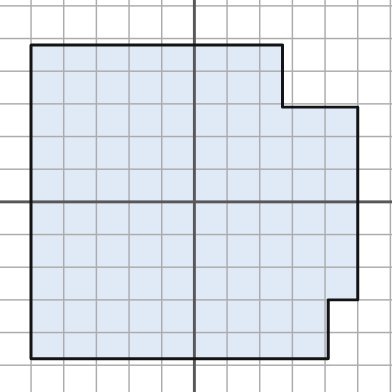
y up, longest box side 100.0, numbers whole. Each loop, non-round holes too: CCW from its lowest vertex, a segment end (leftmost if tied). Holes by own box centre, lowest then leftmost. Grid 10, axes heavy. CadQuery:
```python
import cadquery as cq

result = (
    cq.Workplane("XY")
    .moveTo(-50.0, -48.0)
    .lineTo(41.0, -48.0)
    .lineTo(41.0, -30.0)
    .lineTo(50.0, -30.0)
    .lineTo(50.0, 29.0)
    .lineTo(27.0, 29.0)
    .lineTo(27.0, 48.0)
    .lineTo(-50.0, 48.0)
    .close()
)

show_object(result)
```